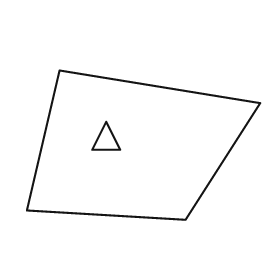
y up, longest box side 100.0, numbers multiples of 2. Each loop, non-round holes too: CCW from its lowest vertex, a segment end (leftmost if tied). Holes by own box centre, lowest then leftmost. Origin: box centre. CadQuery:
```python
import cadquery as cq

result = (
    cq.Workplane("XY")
    .moveTo(18.0, -32.0)
    .lineTo(50.0, 18.0)
    .lineTo(-36.0, 32.0)
    .lineTo(-50.0, -28.0)
    .close()
    .moveTo(-22.0, -2.0)
    .lineTo(-10.0, -2.0)
    .lineTo(-16.0, 10.0)
    .close()
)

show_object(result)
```